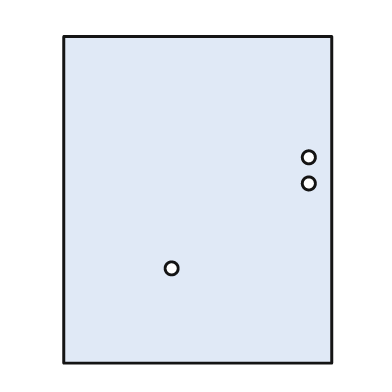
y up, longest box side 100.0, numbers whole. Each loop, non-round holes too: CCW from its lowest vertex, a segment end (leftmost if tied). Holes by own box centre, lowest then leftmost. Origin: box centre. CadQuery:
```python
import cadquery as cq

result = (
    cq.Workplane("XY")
    .moveTo(-41.0, -50.0)
    .lineTo(41.0, -50.0)
    .lineTo(41.0, 50.0)
    .lineTo(-41.0, 50.0)
    .close()
    .moveTo(-8.0, -21.0)
    .circle(2.0)
    .moveTo(34.0, 5.0)
    .circle(2.0)
    .moveTo(34.0, 13.0)
    .circle(2.0)
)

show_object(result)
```